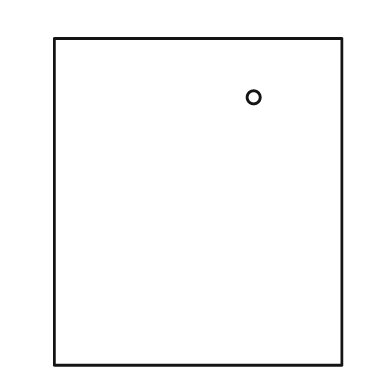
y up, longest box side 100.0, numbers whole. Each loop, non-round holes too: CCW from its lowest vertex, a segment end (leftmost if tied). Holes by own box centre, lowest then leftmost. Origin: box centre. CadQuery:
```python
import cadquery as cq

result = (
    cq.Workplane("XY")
    .moveTo(-44.0, -50.0)
    .lineTo(44.0, -50.0)
    .lineTo(44.0, 50.0)
    .lineTo(-44.0, 50.0)
    .close()
    .moveTo(17.0, 32.0)
    .circle(2.0)
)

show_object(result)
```